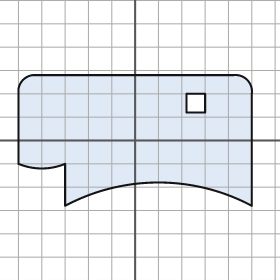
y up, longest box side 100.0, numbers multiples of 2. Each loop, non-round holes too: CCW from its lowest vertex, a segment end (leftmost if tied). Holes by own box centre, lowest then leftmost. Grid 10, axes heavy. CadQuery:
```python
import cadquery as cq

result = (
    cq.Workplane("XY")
    .moveTo(-30.0, -28.0)
    .threePointArc((10.0, -18.0), (50.0, -28.0))
    .lineTo(50.0, 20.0)
    .threePointArc((48.0, 26.0), (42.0, 28.0))
    .lineTo(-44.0, 28.0)
    .threePointArc((-48.0, 26.0), (-50.0, 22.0))
    .lineTo(-50.0, -10.0)
    .threePointArc((-40.0, -12.0), (-30.0, -10.0))
    .close()
    .moveTo(22.0, 12.0)
    .lineTo(30.0, 12.0)
    .lineTo(30.0, 20.0)
    .lineTo(22.0, 20.0)
    .close()
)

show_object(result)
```